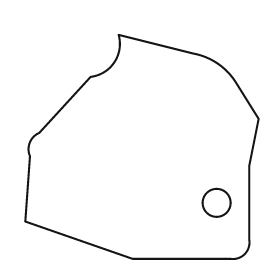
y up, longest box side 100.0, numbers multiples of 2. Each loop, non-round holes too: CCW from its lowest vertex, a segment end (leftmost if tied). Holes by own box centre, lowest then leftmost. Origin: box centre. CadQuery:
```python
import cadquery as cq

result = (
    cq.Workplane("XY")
    .moveTo(-4.0, -48.0)
    .lineTo(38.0, -48.0)
    .threePointArc((44.0, -46.0), (46.0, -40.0))
    .lineTo(46.0, -8.0)
    .lineTo(50.0, 12.0)
    .lineTo(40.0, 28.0)
    .threePointArc((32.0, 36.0), (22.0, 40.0))
    .lineTo(-10.0, 48.0)
    .threePointArc((-12.0, 36.0), (-22.0, 30.0))
    .lineTo(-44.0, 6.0)
    .threePointArc((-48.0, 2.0), (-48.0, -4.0))
    .lineTo(-50.0, -32.0)
    .close()
    .moveTo(32.0, -24.0)
    .circle(6.0)
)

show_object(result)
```